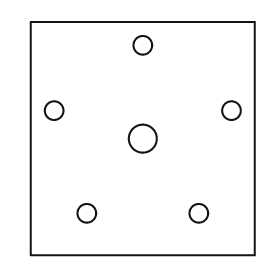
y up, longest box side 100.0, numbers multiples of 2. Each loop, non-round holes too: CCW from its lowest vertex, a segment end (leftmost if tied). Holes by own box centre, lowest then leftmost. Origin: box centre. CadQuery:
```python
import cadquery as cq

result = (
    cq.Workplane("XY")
    .moveTo(-48.0, -50.0)
    .lineTo(48.0, -50.0)
    .lineTo(48.0, 50.0)
    .lineTo(-48.0, 50.0)
    .close()
    .moveTo(-24.0, -32.0)
    .circle(4.0)
    .moveTo(24.0, -32.0)
    .circle(4.0)
    .moveTo(0.0, 0.0)
    .circle(6.0)
    .moveTo(-38.0, 12.0)
    .circle(4.0)
    .moveTo(38.0, 12.0)
    .circle(4.0)
    .moveTo(0.0, 40.0)
    .circle(4.0)
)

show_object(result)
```